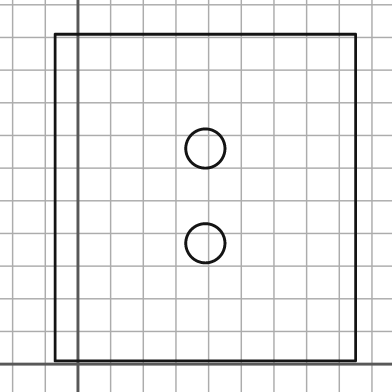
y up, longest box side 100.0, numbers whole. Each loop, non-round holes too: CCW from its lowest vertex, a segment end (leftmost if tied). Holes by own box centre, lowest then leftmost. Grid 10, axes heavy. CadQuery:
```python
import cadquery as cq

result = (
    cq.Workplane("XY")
    .moveTo(-7.0, 1.0)
    .lineTo(85.0, 1.0)
    .lineTo(85.0, 101.0)
    .lineTo(-7.0, 101.0)
    .close()
    .moveTo(39.0, 37.0)
    .circle(6.0)
    .moveTo(39.0, 66.0)
    .circle(6.0)
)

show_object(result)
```